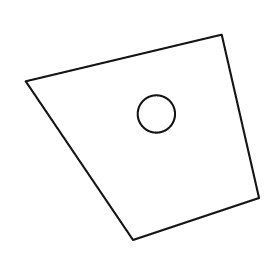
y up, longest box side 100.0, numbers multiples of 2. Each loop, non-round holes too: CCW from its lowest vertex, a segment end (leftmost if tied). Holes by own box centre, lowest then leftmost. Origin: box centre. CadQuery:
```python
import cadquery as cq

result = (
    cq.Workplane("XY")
    .moveTo(-4.0, -44.0)
    .lineTo(50.0, -26.0)
    .lineTo(34.0, 44.0)
    .lineTo(-50.0, 24.0)
    .close()
    .moveTo(6.0, 10.0)
    .circle(8.0)
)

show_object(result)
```